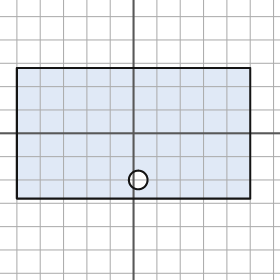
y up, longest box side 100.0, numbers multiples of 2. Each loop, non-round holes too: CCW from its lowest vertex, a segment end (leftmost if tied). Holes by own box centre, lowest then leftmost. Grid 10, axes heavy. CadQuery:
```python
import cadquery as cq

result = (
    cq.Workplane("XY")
    .moveTo(-50.0, -28.0)
    .lineTo(50.0, -28.0)
    .lineTo(50.0, 28.0)
    .lineTo(-50.0, 28.0)
    .close()
    .moveTo(2.0, -20.0)
    .circle(4.0)
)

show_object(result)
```